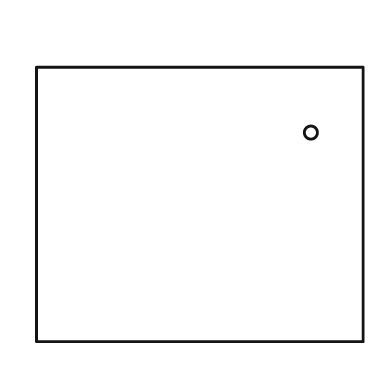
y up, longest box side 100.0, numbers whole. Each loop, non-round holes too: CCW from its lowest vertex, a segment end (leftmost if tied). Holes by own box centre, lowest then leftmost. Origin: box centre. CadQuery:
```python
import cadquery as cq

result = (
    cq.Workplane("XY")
    .moveTo(-50.0, -42.0)
    .lineTo(50.0, -42.0)
    .lineTo(50.0, 42.0)
    .lineTo(-50.0, 42.0)
    .close()
    .moveTo(34.0, 22.0)
    .circle(2.0)
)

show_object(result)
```